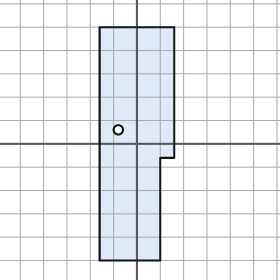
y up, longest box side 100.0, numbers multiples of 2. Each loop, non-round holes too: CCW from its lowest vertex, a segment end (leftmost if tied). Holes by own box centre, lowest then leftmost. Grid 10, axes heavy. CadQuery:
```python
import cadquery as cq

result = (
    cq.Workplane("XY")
    .moveTo(-16.0, -50.0)
    .lineTo(10.0, -50.0)
    .lineTo(10.0, -6.0)
    .lineTo(16.0, -6.0)
    .lineTo(16.0, 50.0)
    .lineTo(-16.0, 50.0)
    .close()
    .moveTo(-8.0, 6.0)
    .circle(2.0)
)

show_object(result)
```